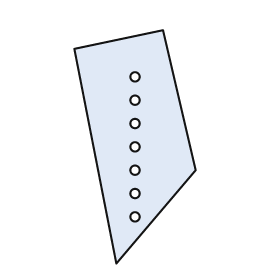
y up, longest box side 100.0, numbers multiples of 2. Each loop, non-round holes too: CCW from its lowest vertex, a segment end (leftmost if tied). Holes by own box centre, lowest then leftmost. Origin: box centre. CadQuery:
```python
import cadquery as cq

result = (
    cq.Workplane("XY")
    .moveTo(-8.0, -50.0)
    .lineTo(26.0, -10.0)
    .lineTo(12.0, 50.0)
    .lineTo(-26.0, 42.0)
    .close()
    .moveTo(0.0, -30.0)
    .circle(2.0)
    .moveTo(0.0, -20.0)
    .circle(2.0)
    .moveTo(0.0, -10.0)
    .circle(2.0)
    .moveTo(0.0, 0.0)
    .circle(2.0)
    .moveTo(0.0, 10.0)
    .circle(2.0)
    .moveTo(0.0, 20.0)
    .circle(2.0)
    .moveTo(0.0, 30.0)
    .circle(2.0)
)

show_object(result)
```